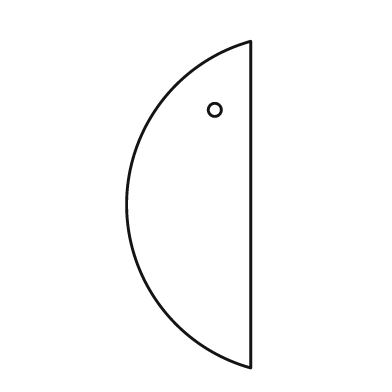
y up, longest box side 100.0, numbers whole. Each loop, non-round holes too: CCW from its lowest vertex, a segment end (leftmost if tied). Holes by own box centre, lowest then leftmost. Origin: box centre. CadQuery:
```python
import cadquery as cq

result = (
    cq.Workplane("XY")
    .moveTo(19.0, -50.0)
    .lineTo(19.0, 50.0)
    .threePointArc((-19.0, 0.0), (19.0, -50.0))
    .close()
    .moveTo(8.0, 29.0)
    .circle(2.0)
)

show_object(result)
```